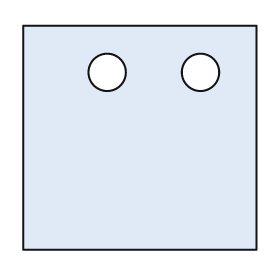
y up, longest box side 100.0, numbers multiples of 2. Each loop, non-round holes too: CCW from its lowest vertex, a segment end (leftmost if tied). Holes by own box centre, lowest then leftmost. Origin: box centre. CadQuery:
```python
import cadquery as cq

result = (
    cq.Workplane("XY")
    .moveTo(-50.0, -48.0)
    .lineTo(50.0, -48.0)
    .lineTo(50.0, 48.0)
    .lineTo(-50.0, 48.0)
    .close()
    .moveTo(-14.0, 28.0)
    .circle(8.0)
    .moveTo(26.0, 28.0)
    .circle(8.0)
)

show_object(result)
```